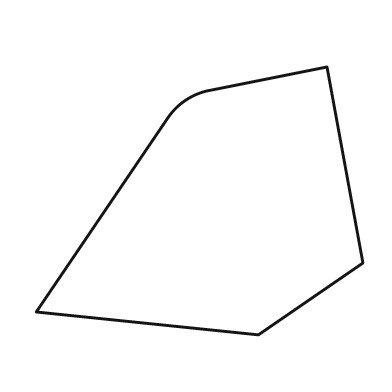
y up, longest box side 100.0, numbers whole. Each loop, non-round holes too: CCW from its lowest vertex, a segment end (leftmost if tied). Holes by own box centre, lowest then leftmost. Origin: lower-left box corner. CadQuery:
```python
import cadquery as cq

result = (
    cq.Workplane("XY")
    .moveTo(68.0, 0.0)
    .lineTo(100.0, 22.0)
    .lineTo(89.0, 82.0)
    .lineTo(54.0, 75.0)
    .threePointArc((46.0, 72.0), (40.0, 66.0))
    .lineTo(0.0, 7.0)
    .close()
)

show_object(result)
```